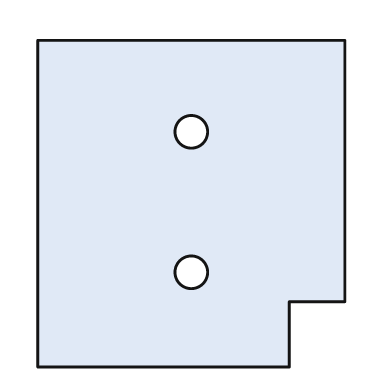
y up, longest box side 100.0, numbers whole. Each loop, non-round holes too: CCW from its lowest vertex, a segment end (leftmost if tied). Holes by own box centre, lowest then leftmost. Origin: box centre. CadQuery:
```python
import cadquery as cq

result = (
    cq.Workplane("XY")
    .moveTo(-47.0, -50.0)
    .lineTo(30.0, -50.0)
    .lineTo(30.0, -30.0)
    .lineTo(47.0, -30.0)
    .lineTo(47.0, 50.0)
    .lineTo(-47.0, 50.0)
    .close()
    .moveTo(0.0, -21.0)
    .circle(5.0)
    .moveTo(0.0, 22.0)
    .circle(5.0)
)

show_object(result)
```